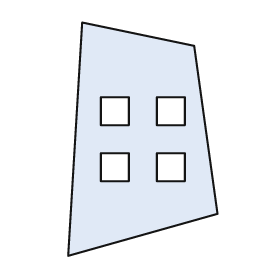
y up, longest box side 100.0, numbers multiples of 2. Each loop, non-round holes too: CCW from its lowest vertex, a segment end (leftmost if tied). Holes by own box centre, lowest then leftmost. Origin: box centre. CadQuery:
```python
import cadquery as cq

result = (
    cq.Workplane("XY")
    .moveTo(-32.0, -50.0)
    .lineTo(32.0, -32.0)
    .lineTo(22.0, 40.0)
    .lineTo(-26.0, 50.0)
    .close()
    .moveTo(-18.0, -18.0)
    .lineTo(-6.0, -18.0)
    .lineTo(-6.0, -6.0)
    .lineTo(-18.0, -6.0)
    .close()
    .moveTo(6.0, -18.0)
    .lineTo(18.0, -18.0)
    .lineTo(18.0, -6.0)
    .lineTo(6.0, -6.0)
    .close()
    .moveTo(-18.0, 6.0)
    .lineTo(-6.0, 6.0)
    .lineTo(-6.0, 18.0)
    .lineTo(-18.0, 18.0)
    .close()
    .moveTo(6.0, 6.0)
    .lineTo(18.0, 6.0)
    .lineTo(18.0, 18.0)
    .lineTo(6.0, 18.0)
    .close()
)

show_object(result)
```